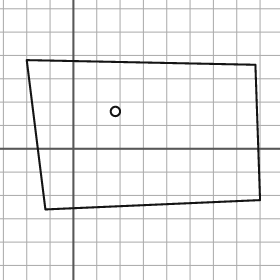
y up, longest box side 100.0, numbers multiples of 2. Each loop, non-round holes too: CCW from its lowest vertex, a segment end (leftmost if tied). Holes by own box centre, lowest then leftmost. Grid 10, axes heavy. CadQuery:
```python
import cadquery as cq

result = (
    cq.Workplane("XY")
    .moveTo(-12.0, -26.0)
    .lineTo(80.0, -22.0)
    .lineTo(78.0, 36.0)
    .lineTo(-20.0, 38.0)
    .close()
    .moveTo(18.0, 16.0)
    .circle(2.0)
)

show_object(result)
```